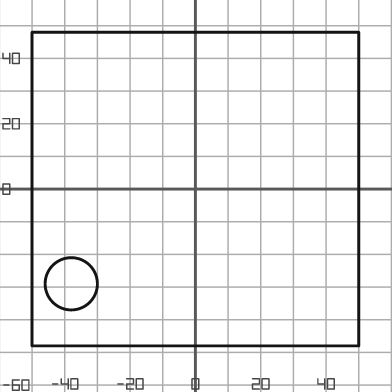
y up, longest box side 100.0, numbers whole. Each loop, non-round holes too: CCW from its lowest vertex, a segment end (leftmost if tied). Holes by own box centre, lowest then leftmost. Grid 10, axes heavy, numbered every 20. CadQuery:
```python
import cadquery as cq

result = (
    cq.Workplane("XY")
    .moveTo(-50.0, -48.0)
    .lineTo(50.0, -48.0)
    .lineTo(50.0, 48.0)
    .lineTo(-50.0, 48.0)
    .close()
    .moveTo(-38.0, -29.0)
    .circle(8.0)
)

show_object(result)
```